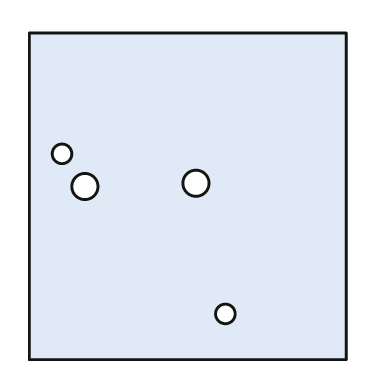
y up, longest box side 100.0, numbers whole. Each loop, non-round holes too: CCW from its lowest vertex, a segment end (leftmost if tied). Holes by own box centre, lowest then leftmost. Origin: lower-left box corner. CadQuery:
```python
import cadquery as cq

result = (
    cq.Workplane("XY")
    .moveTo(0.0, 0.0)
    .lineTo(97.0, 0.0)
    .lineTo(97.0, 100.0)
    .lineTo(0.0, 100.0)
    .close()
    .moveTo(60.0, 14.0)
    .circle(3.0)
    .moveTo(17.0, 53.0)
    .circle(4.0)
    .moveTo(51.0, 54.0)
    .circle(4.0)
    .moveTo(10.0, 63.0)
    .circle(3.0)
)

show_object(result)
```